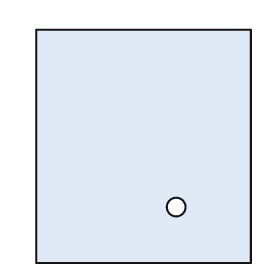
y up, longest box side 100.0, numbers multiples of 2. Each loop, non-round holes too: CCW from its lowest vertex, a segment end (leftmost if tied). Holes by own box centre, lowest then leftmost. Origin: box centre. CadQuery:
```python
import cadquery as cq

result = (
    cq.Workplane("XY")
    .moveTo(-46.0, -50.0)
    .lineTo(46.0, -50.0)
    .lineTo(46.0, 50.0)
    .lineTo(-46.0, 50.0)
    .close()
    .moveTo(14.0, -26.0)
    .circle(4.0)
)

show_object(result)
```